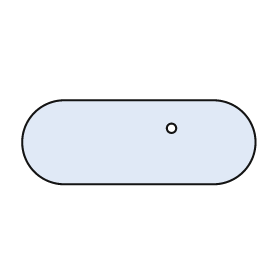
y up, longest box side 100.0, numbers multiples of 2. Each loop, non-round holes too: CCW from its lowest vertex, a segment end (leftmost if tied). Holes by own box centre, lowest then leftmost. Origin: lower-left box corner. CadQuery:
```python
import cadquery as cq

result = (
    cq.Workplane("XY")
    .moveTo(18.0, 0.0)
    .lineTo(82.0, 0.0)
    .threePointArc((100.0, 18.0), (82.0, 36.0))
    .lineTo(18.0, 36.0)
    .threePointArc((0.0, 18.0), (18.0, 0.0))
    .close()
    .moveTo(64.0, 24.0)
    .circle(2.0)
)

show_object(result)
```